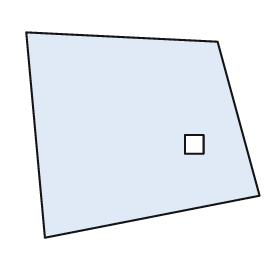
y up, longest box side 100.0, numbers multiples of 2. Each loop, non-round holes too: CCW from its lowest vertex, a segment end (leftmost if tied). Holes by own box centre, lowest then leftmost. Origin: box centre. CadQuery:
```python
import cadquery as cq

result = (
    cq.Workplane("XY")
    .moveTo(-42.0, -44.0)
    .lineTo(50.0, -26.0)
    .lineTo(32.0, 40.0)
    .lineTo(-50.0, 44.0)
    .close()
    .moveTo(18.0, -8.0)
    .lineTo(26.0, -8.0)
    .lineTo(26.0, 0.0)
    .lineTo(18.0, 0.0)
    .close()
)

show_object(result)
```